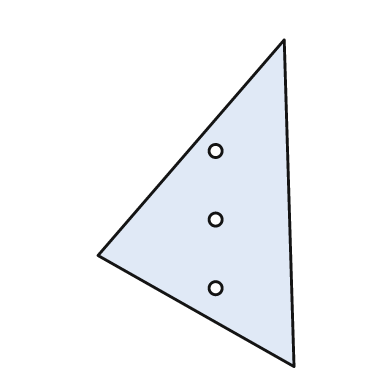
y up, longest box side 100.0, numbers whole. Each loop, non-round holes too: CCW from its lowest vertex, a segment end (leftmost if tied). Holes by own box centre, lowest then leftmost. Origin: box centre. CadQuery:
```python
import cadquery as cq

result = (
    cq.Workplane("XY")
    .moveTo(30.0, -50.0)
    .lineTo(27.0, 50.0)
    .lineTo(-30.0, -16.0)
    .close()
    .moveTo(6.0, -26.0)
    .circle(2.0)
    .moveTo(6.0, -5.0)
    .circle(2.0)
    .moveTo(6.0, 16.0)
    .circle(2.0)
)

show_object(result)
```